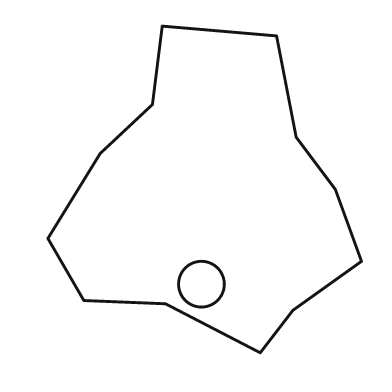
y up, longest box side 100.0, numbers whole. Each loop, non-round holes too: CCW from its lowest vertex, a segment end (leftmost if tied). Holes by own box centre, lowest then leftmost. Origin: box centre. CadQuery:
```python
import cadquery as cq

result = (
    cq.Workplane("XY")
    .moveTo(17.0, -50.0)
    .lineTo(27.0, -37.0)
    .lineTo(48.0, -22.0)
    .lineTo(40.0, 0.0)
    .lineTo(28.0, 16.0)
    .lineTo(22.0, 47.0)
    .lineTo(-13.0, 50.0)
    .lineTo(-16.0, 26.0)
    .lineTo(-32.0, 11.0)
    .lineTo(-48.0, -15.0)
    .lineTo(-37.0, -34.0)
    .lineTo(-12.0, -35.0)
    .close()
    .moveTo(-1.0, -29.0)
    .circle(7.0)
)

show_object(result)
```